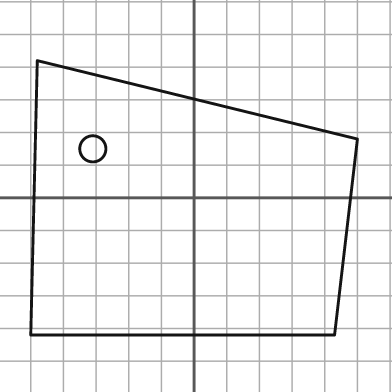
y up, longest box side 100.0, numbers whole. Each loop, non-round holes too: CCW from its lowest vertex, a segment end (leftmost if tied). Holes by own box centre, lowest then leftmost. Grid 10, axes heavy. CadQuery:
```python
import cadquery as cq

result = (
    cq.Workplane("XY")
    .moveTo(-50.0, -42.0)
    .lineTo(43.0, -42.0)
    .lineTo(50.0, 18.0)
    .lineTo(-48.0, 42.0)
    .close()
    .moveTo(-31.0, 15.0)
    .circle(4.0)
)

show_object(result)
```